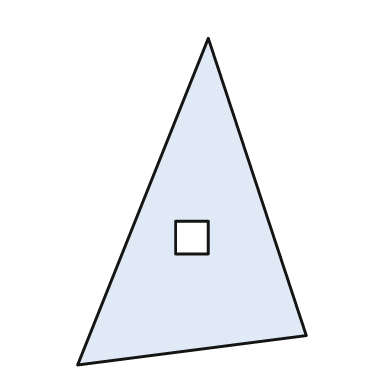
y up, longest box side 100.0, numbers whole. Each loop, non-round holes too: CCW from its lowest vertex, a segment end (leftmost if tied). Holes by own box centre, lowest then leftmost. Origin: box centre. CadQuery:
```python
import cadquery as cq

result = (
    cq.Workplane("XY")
    .moveTo(-35.0, -50.0)
    .lineTo(35.0, -41.0)
    .lineTo(5.0, 50.0)
    .close()
    .moveTo(-5.0, -16.0)
    .lineTo(5.0, -16.0)
    .lineTo(5.0, -6.0)
    .lineTo(-5.0, -6.0)
    .close()
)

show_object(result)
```